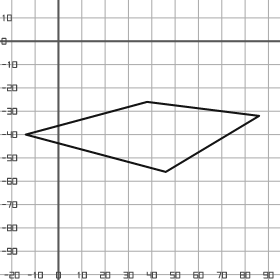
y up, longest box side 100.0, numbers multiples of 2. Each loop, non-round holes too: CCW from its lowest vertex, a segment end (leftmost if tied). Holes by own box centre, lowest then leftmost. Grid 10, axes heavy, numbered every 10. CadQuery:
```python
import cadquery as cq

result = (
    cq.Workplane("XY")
    .moveTo(46.0, -56.0)
    .lineTo(86.0, -32.0)
    .lineTo(38.0, -26.0)
    .lineTo(-14.0, -40.0)
    .close()
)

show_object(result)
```